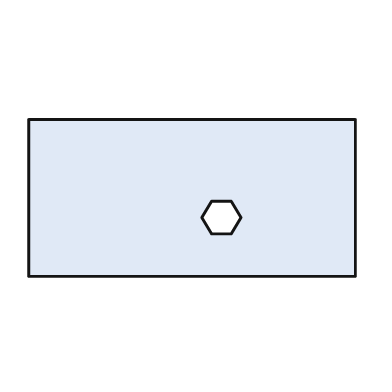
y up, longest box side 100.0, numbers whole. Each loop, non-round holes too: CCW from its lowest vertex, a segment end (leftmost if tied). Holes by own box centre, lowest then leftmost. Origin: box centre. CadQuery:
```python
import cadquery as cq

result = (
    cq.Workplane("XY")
    .moveTo(-50.0, -24.0)
    .lineTo(50.0, -24.0)
    .lineTo(50.0, 24.0)
    .lineTo(-50.0, 24.0)
    .close()
    .moveTo(6.0, -11.0)
    .lineTo(12.0, -11.0)
    .lineTo(15.0, -6.0)
    .lineTo(12.0, -1.0)
    .lineTo(6.0, -1.0)
    .lineTo(3.0, -6.0)
    .close()
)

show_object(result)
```